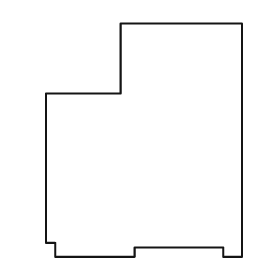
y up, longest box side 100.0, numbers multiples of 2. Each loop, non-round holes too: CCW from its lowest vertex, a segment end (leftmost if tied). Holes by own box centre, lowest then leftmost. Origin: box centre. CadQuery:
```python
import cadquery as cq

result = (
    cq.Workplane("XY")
    .moveTo(-38.0, -50.0)
    .lineTo(-4.0, -50.0)
    .lineTo(-4.0, -46.0)
    .lineTo(34.0, -46.0)
    .lineTo(34.0, -50.0)
    .lineTo(42.0, -50.0)
    .lineTo(42.0, 50.0)
    .lineTo(-10.0, 50.0)
    .lineTo(-10.0, 20.0)
    .lineTo(-42.0, 20.0)
    .lineTo(-42.0, -44.0)
    .lineTo(-38.0, -44.0)
    .close()
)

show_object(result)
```